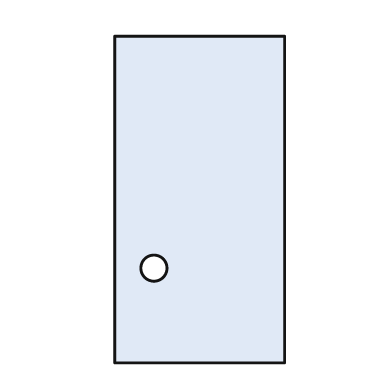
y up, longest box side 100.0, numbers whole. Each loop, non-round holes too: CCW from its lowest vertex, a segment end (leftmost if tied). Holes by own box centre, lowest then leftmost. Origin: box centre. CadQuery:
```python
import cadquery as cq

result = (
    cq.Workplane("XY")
    .moveTo(-26.0, -50.0)
    .lineTo(26.0, -50.0)
    .lineTo(26.0, 50.0)
    .lineTo(-26.0, 50.0)
    .close()
    .moveTo(-14.0, -21.0)
    .circle(4.0)
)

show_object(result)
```